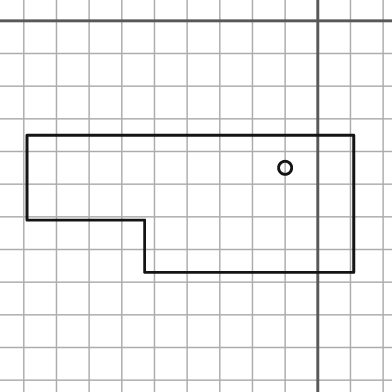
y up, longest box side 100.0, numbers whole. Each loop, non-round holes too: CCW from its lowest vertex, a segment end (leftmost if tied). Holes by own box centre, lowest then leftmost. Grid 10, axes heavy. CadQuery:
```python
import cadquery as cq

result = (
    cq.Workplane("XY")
    .moveTo(-53.0, -77.0)
    .lineTo(11.0, -77.0)
    .lineTo(11.0, -35.0)
    .lineTo(-89.0, -35.0)
    .lineTo(-89.0, -61.0)
    .lineTo(-53.0, -61.0)
    .close()
    .moveTo(-10.0, -45.0)
    .circle(2.0)
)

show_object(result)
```